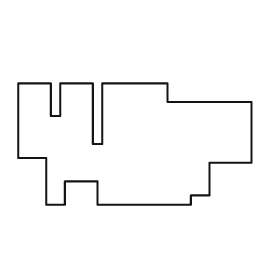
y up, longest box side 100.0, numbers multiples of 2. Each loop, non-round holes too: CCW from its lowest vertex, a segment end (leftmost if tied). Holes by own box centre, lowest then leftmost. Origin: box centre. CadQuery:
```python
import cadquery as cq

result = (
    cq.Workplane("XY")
    .moveTo(-38.0, -26.0)
    .lineTo(-30.0, -26.0)
    .lineTo(-30.0, -16.0)
    .lineTo(-16.0, -16.0)
    .lineTo(-16.0, -26.0)
    .lineTo(24.0, -26.0)
    .lineTo(24.0, -22.0)
    .lineTo(32.0, -22.0)
    .lineTo(32.0, -8.0)
    .lineTo(50.0, -8.0)
    .lineTo(50.0, 18.0)
    .lineTo(14.0, 18.0)
    .lineTo(14.0, 26.0)
    .lineTo(-14.0, 26.0)
    .lineTo(-14.0, 0.0)
    .lineTo(-18.0, 0.0)
    .lineTo(-18.0, 26.0)
    .lineTo(-32.0, 26.0)
    .lineTo(-32.0, 12.0)
    .lineTo(-36.0, 12.0)
    .lineTo(-36.0, 26.0)
    .lineTo(-50.0, 26.0)
    .lineTo(-50.0, -6.0)
    .lineTo(-38.0, -6.0)
    .close()
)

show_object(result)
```